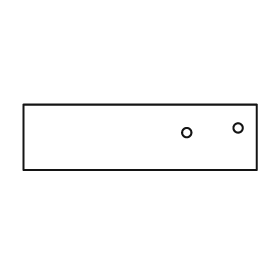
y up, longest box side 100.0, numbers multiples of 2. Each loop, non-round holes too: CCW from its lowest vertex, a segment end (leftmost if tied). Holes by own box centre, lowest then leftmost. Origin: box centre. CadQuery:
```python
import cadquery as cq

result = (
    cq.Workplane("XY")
    .moveTo(-50.0, -14.0)
    .lineTo(50.0, -14.0)
    .lineTo(50.0, 14.0)
    .lineTo(-50.0, 14.0)
    .close()
    .moveTo(20.0, 2.0)
    .circle(2.0)
    .moveTo(42.0, 4.0)
    .circle(2.0)
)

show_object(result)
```